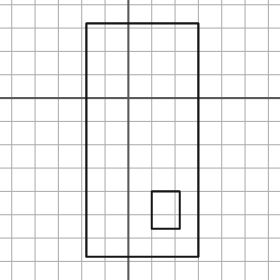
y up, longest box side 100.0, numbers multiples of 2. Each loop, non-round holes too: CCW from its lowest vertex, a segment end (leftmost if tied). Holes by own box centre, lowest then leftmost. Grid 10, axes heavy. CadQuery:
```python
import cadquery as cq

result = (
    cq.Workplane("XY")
    .moveTo(-18.0, -68.0)
    .lineTo(30.0, -68.0)
    .lineTo(30.0, 32.0)
    .lineTo(-18.0, 32.0)
    .close()
    .moveTo(10.0, -56.0)
    .lineTo(22.0, -56.0)
    .lineTo(22.0, -40.0)
    .lineTo(10.0, -40.0)
    .close()
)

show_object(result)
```